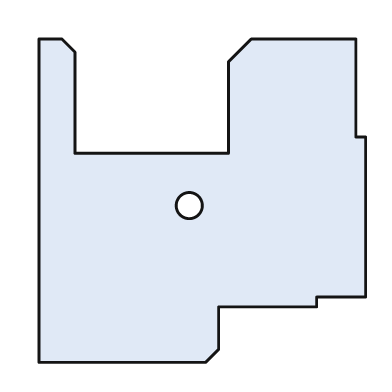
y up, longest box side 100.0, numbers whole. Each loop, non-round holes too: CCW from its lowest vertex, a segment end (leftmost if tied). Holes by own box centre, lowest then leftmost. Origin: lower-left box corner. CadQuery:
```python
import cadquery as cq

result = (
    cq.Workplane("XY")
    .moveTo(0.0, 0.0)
    .lineTo(51.0, 0.0)
    .lineTo(55.0, 4.0)
    .lineTo(55.0, 17.0)
    .lineTo(85.0, 17.0)
    .lineTo(85.0, 20.0)
    .lineTo(100.0, 20.0)
    .lineTo(100.0, 69.0)
    .lineTo(97.0, 69.0)
    .lineTo(97.0, 99.0)
    .lineTo(65.0, 99.0)
    .lineTo(58.0, 92.0)
    .lineTo(58.0, 64.0)
    .lineTo(11.0, 64.0)
    .lineTo(11.0, 95.0)
    .lineTo(7.0, 99.0)
    .lineTo(0.0, 99.0)
    .close()
    .moveTo(46.0, 48.0)
    .circle(4.0)
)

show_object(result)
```